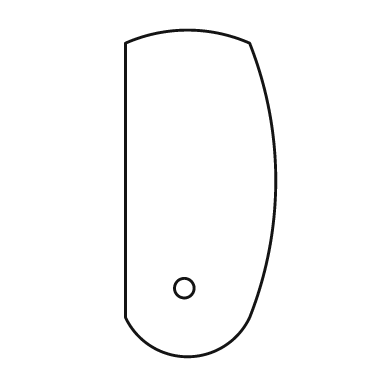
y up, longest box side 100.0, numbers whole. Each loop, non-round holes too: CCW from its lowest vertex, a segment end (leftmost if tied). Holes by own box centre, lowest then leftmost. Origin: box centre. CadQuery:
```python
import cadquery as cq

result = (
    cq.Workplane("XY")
    .moveTo(-23.0, -38.0)
    .threePointArc((-4.0, -50.0), (15.0, -38.0))
    .threePointArc((23.0, 4.0), (15.0, 46.0))
    .threePointArc((-4.0, 50.0), (-23.0, 46.0))
    .close()
    .moveTo(-5.0, -29.0)
    .circle(3.0)
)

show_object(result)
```